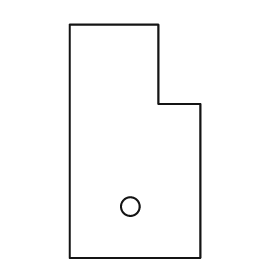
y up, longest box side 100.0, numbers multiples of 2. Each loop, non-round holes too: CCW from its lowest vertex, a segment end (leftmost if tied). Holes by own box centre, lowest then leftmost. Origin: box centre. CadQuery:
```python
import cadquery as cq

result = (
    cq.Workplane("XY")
    .moveTo(-28.0, -50.0)
    .lineTo(28.0, -50.0)
    .lineTo(28.0, 16.0)
    .lineTo(10.0, 16.0)
    .lineTo(10.0, 50.0)
    .lineTo(-28.0, 50.0)
    .close()
    .moveTo(-2.0, -28.0)
    .circle(4.0)
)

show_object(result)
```